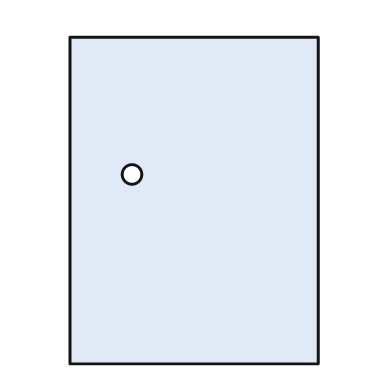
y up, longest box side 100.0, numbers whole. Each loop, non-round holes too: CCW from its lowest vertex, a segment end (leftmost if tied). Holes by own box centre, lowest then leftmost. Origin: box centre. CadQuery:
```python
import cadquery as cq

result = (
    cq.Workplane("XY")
    .moveTo(-38.0, -50.0)
    .lineTo(38.0, -50.0)
    .lineTo(38.0, 50.0)
    .lineTo(-38.0, 50.0)
    .close()
    .moveTo(-19.0, 8.0)
    .circle(3.0)
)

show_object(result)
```